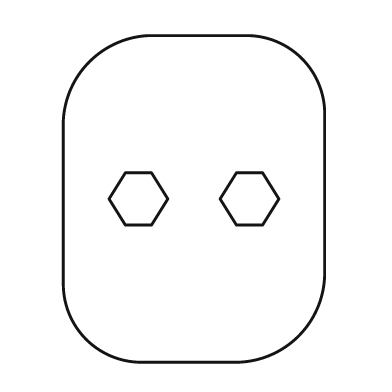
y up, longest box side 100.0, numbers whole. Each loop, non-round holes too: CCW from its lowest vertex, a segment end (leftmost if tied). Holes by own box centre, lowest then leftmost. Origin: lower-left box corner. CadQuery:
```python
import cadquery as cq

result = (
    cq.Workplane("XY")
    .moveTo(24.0, 0.0)
    .lineTo(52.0, 0.0)
    .threePointArc((72.0, 8.0), (80.0, 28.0))
    .lineTo(80.0, 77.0)
    .threePointArc((73.0, 93.0), (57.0, 100.0))
    .lineTo(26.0, 100.0)
    .threePointArc((8.0, 92.0), (0.0, 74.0))
    .lineTo(0.0, 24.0)
    .threePointArc((7.0, 7.0), (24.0, 0.0))
    .close()
    .moveTo(19.0, 42.0)
    .lineTo(27.0, 42.0)
    .lineTo(32.0, 50.0)
    .lineTo(27.0, 58.0)
    .lineTo(19.0, 58.0)
    .lineTo(14.0, 50.0)
    .close()
    .moveTo(53.0, 42.0)
    .lineTo(61.0, 42.0)
    .lineTo(66.0, 50.0)
    .lineTo(61.0, 58.0)
    .lineTo(53.0, 58.0)
    .lineTo(48.0, 50.0)
    .close()
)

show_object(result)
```